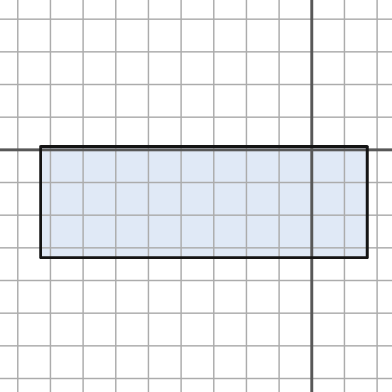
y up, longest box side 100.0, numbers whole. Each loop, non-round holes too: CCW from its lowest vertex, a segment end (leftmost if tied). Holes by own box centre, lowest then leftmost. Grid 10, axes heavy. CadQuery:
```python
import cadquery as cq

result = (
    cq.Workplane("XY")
    .moveTo(-83.0, -33.0)
    .lineTo(17.0, -33.0)
    .lineTo(17.0, 1.0)
    .lineTo(-83.0, 1.0)
    .close()
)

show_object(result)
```